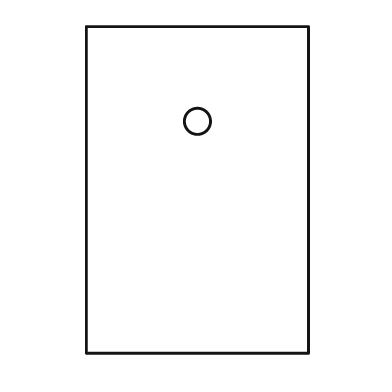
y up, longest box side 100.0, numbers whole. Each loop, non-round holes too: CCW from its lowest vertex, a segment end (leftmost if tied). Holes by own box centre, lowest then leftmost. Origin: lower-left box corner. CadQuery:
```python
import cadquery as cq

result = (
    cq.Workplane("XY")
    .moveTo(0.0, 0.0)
    .lineTo(68.0, 0.0)
    .lineTo(68.0, 100.0)
    .lineTo(0.0, 100.0)
    .close()
    .moveTo(34.0, 71.0)
    .circle(4.0)
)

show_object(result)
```